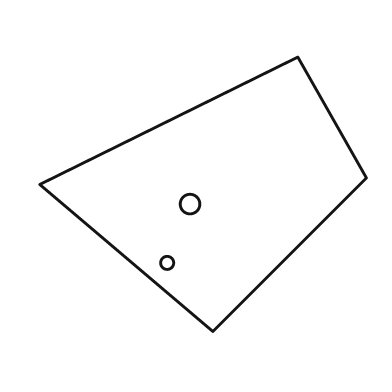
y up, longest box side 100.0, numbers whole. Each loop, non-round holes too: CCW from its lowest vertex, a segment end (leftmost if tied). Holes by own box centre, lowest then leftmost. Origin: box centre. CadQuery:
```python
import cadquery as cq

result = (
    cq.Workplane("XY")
    .moveTo(3.0, -42.0)
    .lineTo(50.0, 5.0)
    .lineTo(29.0, 42.0)
    .lineTo(-50.0, 3.0)
    .close()
    .moveTo(-11.0, -21.0)
    .circle(2.0)
    .moveTo(-4.0, -3.0)
    .circle(3.0)
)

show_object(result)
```